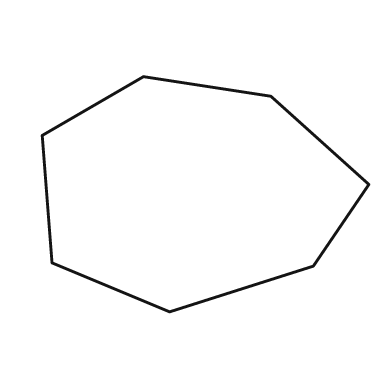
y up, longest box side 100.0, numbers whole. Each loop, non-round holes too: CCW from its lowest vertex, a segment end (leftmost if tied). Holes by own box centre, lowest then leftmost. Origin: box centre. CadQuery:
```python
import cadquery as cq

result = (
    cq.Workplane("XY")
    .moveTo(-11.0, -36.0)
    .lineTo(33.0, -22.0)
    .lineTo(50.0, 3.0)
    .lineTo(20.0, 30.0)
    .lineTo(-19.0, 36.0)
    .lineTo(-50.0, 18.0)
    .lineTo(-47.0, -21.0)
    .close()
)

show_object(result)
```